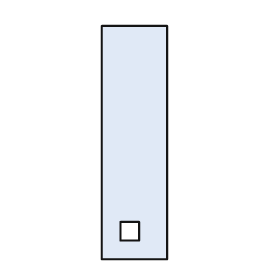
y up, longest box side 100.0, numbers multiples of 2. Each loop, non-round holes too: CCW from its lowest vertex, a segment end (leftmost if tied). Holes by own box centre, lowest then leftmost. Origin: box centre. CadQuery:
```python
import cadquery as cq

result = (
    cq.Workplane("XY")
    .moveTo(-14.0, -50.0)
    .lineTo(14.0, -50.0)
    .lineTo(14.0, 50.0)
    .lineTo(-14.0, 50.0)
    .close()
    .moveTo(-6.0, -42.0)
    .lineTo(2.0, -42.0)
    .lineTo(2.0, -34.0)
    .lineTo(-6.0, -34.0)
    .close()
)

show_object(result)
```